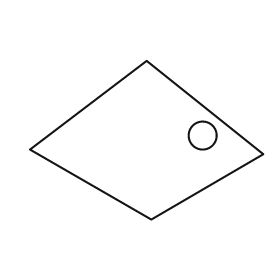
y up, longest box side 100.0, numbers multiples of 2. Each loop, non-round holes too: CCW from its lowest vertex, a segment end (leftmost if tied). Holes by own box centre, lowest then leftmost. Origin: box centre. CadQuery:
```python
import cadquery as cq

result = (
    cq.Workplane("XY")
    .moveTo(2.0, -34.0)
    .lineTo(50.0, -6.0)
    .lineTo(0.0, 34.0)
    .lineTo(-50.0, -4.0)
    .close()
    .moveTo(24.0, 2.0)
    .circle(6.0)
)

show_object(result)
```